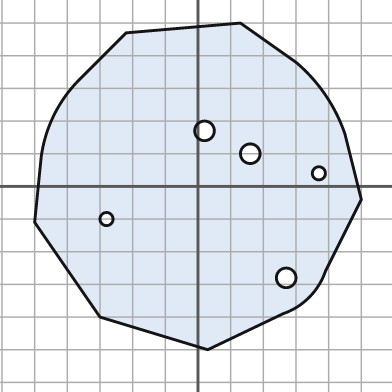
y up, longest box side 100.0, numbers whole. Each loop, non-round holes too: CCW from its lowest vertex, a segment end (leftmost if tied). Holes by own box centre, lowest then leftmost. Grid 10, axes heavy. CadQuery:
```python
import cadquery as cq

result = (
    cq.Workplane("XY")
    .moveTo(3.0, -50.0)
    .lineTo(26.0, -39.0)
    .threePointArc((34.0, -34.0), (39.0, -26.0))
    .lineTo(50.0, -4.0)
    .lineTo(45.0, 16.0)
    .threePointArc((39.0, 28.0), (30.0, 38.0))
    .lineTo(13.0, 50.0)
    .lineTo(-22.0, 47.0)
    .lineTo(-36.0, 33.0)
    .threePointArc((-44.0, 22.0), (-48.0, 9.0))
    .lineTo(-50.0, -11.0)
    .lineTo(-30.0, -40.0)
    .close()
    .moveTo(27.0, -28.0)
    .circle(3.0)
    .moveTo(-28.0, -10.0)
    .circle(2.0)
    .moveTo(37.0, 4.0)
    .circle(2.0)
    .moveTo(16.0, 10.0)
    .circle(3.0)
    .moveTo(2.0, 17.0)
    .circle(3.0)
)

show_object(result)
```